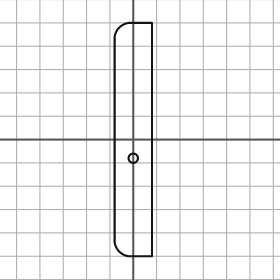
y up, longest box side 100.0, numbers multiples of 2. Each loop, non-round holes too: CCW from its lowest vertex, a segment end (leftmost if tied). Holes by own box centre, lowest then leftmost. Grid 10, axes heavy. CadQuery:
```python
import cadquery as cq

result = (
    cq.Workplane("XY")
    .moveTo(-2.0, -50.0)
    .lineTo(8.0, -50.0)
    .lineTo(8.0, 50.0)
    .lineTo(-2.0, 50.0)
    .threePointArc((-6.0, 48.0), (-8.0, 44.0))
    .lineTo(-8.0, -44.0)
    .threePointArc((-6.0, -48.0), (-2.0, -50.0))
    .close()
    .moveTo(0.0, -8.0)
    .circle(2.0)
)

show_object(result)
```